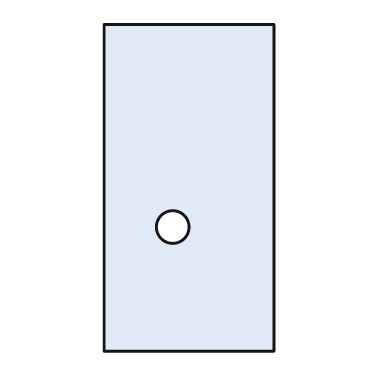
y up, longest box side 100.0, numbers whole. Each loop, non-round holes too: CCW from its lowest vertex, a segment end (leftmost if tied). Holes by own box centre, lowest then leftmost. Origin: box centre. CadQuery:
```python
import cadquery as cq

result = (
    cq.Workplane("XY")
    .moveTo(-26.0, -50.0)
    .lineTo(26.0, -50.0)
    .lineTo(26.0, 50.0)
    .lineTo(-26.0, 50.0)
    .close()
    .moveTo(-5.0, -12.0)
    .circle(5.0)
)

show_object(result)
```